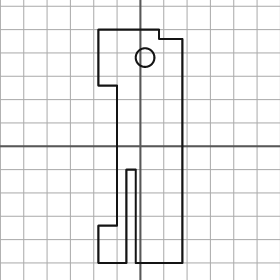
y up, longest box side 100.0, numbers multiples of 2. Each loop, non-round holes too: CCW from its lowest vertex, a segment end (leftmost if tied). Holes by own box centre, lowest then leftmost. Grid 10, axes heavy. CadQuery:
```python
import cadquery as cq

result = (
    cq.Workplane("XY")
    .moveTo(-18.0, -50.0)
    .lineTo(-6.0, -50.0)
    .lineTo(-6.0, -10.0)
    .lineTo(-2.0, -10.0)
    .lineTo(-2.0, -50.0)
    .lineTo(18.0, -50.0)
    .lineTo(18.0, 46.0)
    .lineTo(8.0, 46.0)
    .lineTo(8.0, 50.0)
    .lineTo(-18.0, 50.0)
    .lineTo(-18.0, 26.0)
    .lineTo(-10.0, 26.0)
    .lineTo(-10.0, -34.0)
    .lineTo(-18.0, -34.0)
    .close()
    .moveTo(2.0, 38.0)
    .circle(4.0)
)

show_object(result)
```